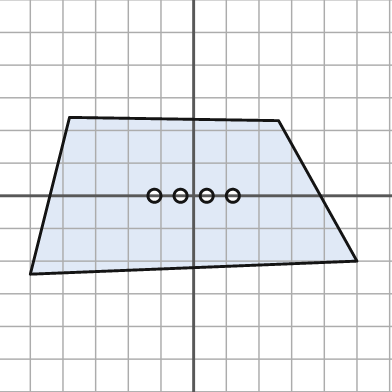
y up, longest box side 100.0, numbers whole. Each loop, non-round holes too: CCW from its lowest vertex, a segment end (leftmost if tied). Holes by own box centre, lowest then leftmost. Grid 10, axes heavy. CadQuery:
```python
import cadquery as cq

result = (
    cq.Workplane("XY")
    .moveTo(-50.0, -24.0)
    .lineTo(50.0, -20.0)
    .lineTo(26.0, 23.0)
    .lineTo(-38.0, 24.0)
    .close()
    .moveTo(-12.0, 0.0)
    .circle(2.0)
    .moveTo(-4.0, 0.0)
    .circle(2.0)
    .moveTo(4.0, 0.0)
    .circle(2.0)
    .moveTo(12.0, 0.0)
    .circle(2.0)
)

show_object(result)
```